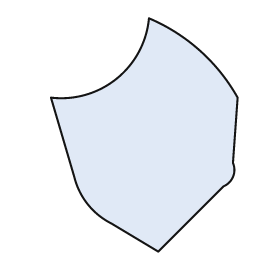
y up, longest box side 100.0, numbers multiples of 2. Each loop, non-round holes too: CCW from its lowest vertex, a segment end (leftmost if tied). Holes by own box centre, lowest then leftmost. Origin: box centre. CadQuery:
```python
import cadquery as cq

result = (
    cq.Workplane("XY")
    .moveTo(6.0, -50.0)
    .lineTo(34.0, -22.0)
    .threePointArc((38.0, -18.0), (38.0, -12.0))
    .lineTo(40.0, 16.0)
    .threePointArc((24.0, 36.0), (2.0, 50.0))
    .threePointArc((-12.0, 24.0), (-40.0, 16.0))
    .lineTo(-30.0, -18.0)
    .threePointArc((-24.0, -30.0), (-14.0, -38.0))
    .close()
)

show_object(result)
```